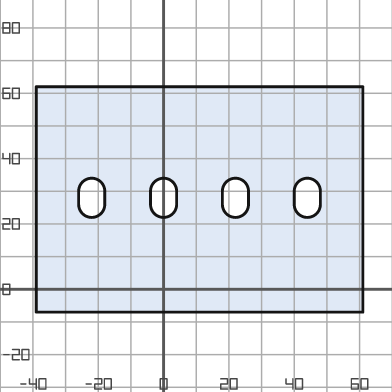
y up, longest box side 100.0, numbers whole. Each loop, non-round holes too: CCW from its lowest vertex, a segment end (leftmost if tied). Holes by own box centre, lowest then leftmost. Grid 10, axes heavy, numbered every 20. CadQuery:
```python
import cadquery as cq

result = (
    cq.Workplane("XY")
    .moveTo(-39.0, -7.0)
    .lineTo(61.0, -7.0)
    .lineTo(61.0, 62.0)
    .lineTo(-39.0, 62.0)
    .close()
    .moveTo(-26.0, 26.0)
    .threePointArc((-22.0, 22.0), (-18.0, 26.0))
    .lineTo(-18.0, 30.0)
    .threePointArc((-22.0, 34.0), (-26.0, 30.0))
    .close()
    .moveTo(-4.0, 26.0)
    .threePointArc((0.0, 22.0), (4.0, 26.0))
    .lineTo(4.0, 30.0)
    .threePointArc((0.0, 34.0), (-4.0, 30.0))
    .close()
    .moveTo(18.0, 26.0)
    .threePointArc((22.0, 22.0), (26.0, 26.0))
    .lineTo(26.0, 30.0)
    .threePointArc((22.0, 34.0), (18.0, 30.0))
    .close()
    .moveTo(40.0, 26.0)
    .threePointArc((44.0, 22.0), (48.0, 26.0))
    .lineTo(48.0, 30.0)
    .threePointArc((44.0, 34.0), (40.0, 30.0))
    .close()
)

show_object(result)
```